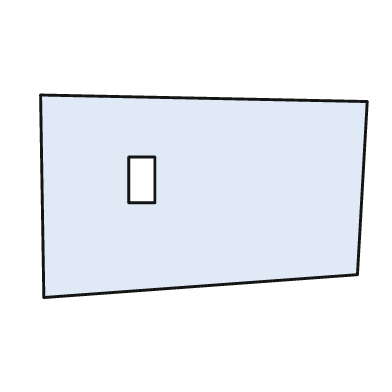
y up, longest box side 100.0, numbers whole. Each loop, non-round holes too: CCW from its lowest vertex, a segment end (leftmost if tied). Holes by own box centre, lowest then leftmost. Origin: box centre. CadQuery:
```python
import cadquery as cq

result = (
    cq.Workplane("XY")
    .moveTo(-49.0, -31.0)
    .lineTo(47.0, -24.0)
    .lineTo(50.0, 29.0)
    .lineTo(-50.0, 31.0)
    .close()
    .moveTo(-23.0, -2.0)
    .lineTo(-15.0, -2.0)
    .lineTo(-15.0, 12.0)
    .lineTo(-23.0, 12.0)
    .close()
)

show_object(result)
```